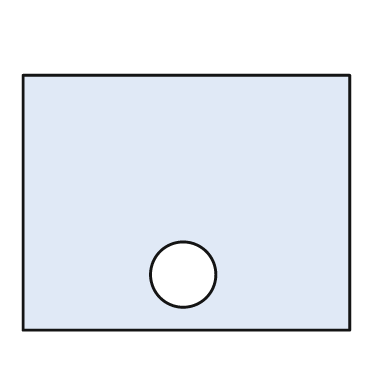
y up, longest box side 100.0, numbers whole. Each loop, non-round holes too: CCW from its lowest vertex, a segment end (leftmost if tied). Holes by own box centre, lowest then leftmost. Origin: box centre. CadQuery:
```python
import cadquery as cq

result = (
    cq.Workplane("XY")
    .moveTo(-50.0, -39.0)
    .lineTo(50.0, -39.0)
    .lineTo(50.0, 39.0)
    .lineTo(-50.0, 39.0)
    .close()
    .moveTo(-1.0, -22.0)
    .circle(10.0)
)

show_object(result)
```